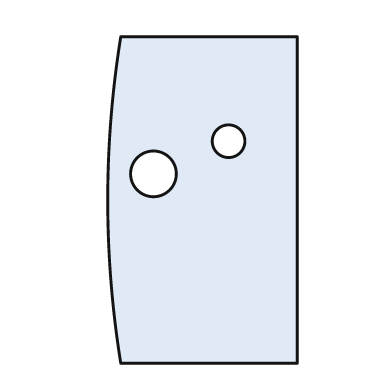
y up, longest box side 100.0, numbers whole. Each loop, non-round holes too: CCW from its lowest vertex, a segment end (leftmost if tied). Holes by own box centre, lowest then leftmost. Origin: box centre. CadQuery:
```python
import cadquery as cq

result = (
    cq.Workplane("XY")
    .moveTo(-25.0, -50.0)
    .lineTo(29.0, -50.0)
    .lineTo(29.0, 50.0)
    .lineTo(-25.0, 50.0)
    .threePointArc((-29.0, 0.0), (-25.0, -50.0))
    .close()
    .moveTo(-15.0, 8.0)
    .circle(7.0)
    .moveTo(8.0, 18.0)
    .circle(5.0)
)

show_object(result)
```